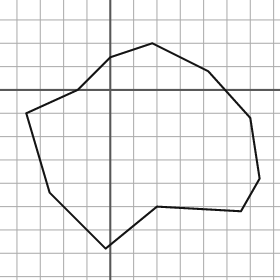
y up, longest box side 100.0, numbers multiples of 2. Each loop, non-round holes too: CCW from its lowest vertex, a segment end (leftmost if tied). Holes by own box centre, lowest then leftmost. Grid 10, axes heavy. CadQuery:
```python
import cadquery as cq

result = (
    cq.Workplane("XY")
    .moveTo(-2.0, -68.0)
    .lineTo(20.0, -50.0)
    .lineTo(56.0, -52.0)
    .lineTo(64.0, -38.0)
    .lineTo(60.0, -12.0)
    .lineTo(42.0, 8.0)
    .lineTo(18.0, 20.0)
    .lineTo(0.0, 14.0)
    .lineTo(-14.0, 0.0)
    .lineTo(-36.0, -10.0)
    .lineTo(-26.0, -44.0)
    .close()
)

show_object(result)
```